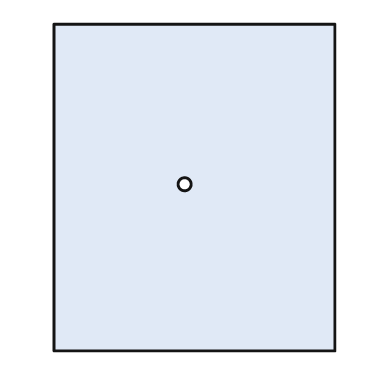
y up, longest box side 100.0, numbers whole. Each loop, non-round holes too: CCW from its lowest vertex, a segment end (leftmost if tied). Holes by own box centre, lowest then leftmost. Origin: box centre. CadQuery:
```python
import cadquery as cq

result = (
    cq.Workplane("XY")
    .moveTo(-43.0, -50.0)
    .lineTo(43.0, -50.0)
    .lineTo(43.0, 50.0)
    .lineTo(-43.0, 50.0)
    .close()
    .moveTo(-3.0, 1.0)
    .circle(2.0)
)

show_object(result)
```